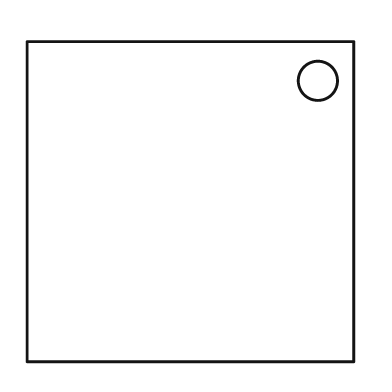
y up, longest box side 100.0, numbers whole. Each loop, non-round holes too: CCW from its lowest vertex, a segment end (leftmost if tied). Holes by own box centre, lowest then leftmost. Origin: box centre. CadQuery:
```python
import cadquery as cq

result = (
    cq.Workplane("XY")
    .moveTo(-50.0, -49.0)
    .lineTo(50.0, -49.0)
    .lineTo(50.0, 49.0)
    .lineTo(-50.0, 49.0)
    .close()
    .moveTo(39.0, 37.0)
    .circle(6.0)
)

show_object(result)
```